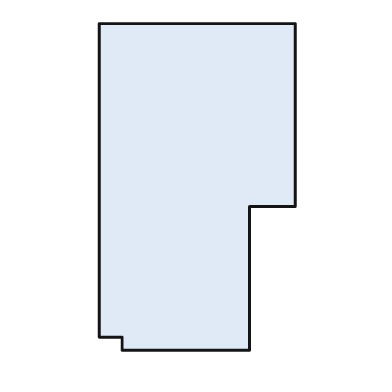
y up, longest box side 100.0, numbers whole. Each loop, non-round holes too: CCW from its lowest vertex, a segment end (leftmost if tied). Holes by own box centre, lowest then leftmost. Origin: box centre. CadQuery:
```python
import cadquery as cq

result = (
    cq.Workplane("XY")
    .moveTo(-23.0, -50.0)
    .lineTo(16.0, -50.0)
    .lineTo(16.0, -6.0)
    .lineTo(30.0, -6.0)
    .lineTo(30.0, 50.0)
    .lineTo(-30.0, 50.0)
    .lineTo(-30.0, -46.0)
    .lineTo(-23.0, -46.0)
    .close()
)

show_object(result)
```